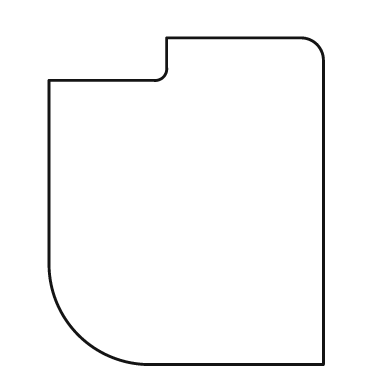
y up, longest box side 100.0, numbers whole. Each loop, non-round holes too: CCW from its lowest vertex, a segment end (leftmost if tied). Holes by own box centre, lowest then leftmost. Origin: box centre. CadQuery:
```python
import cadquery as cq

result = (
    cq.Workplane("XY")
    .moveTo(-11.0, -50.0)
    .lineTo(42.0, -50.0)
    .lineTo(42.0, 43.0)
    .threePointArc((40.0, 48.0), (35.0, 50.0))
    .lineTo(-6.0, 50.0)
    .lineTo(-6.0, 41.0)
    .threePointArc((-7.0, 38.0), (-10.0, 37.0))
    .lineTo(-42.0, 37.0)
    .lineTo(-42.0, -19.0)
    .threePointArc((-33.0, -41.0), (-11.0, -50.0))
    .close()
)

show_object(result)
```